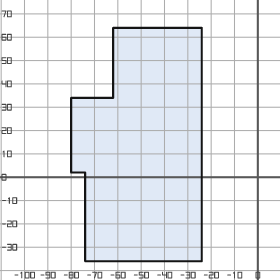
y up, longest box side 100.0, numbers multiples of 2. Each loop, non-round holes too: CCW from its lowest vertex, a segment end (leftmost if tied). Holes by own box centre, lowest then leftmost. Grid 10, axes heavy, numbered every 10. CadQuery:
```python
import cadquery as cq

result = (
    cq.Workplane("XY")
    .moveTo(-74.0, -36.0)
    .lineTo(-24.0, -36.0)
    .lineTo(-24.0, 64.0)
    .lineTo(-62.0, 64.0)
    .lineTo(-62.0, 34.0)
    .lineTo(-80.0, 34.0)
    .lineTo(-80.0, 2.0)
    .lineTo(-74.0, 2.0)
    .close()
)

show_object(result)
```